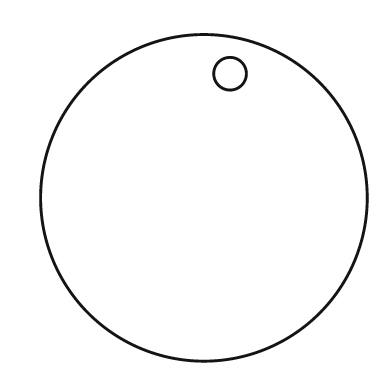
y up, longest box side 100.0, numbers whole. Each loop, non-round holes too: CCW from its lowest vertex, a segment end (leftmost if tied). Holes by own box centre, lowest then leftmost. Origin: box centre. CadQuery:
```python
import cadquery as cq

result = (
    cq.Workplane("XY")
    .moveTo(0.0, 0.0)
    .circle(50.0)
    .moveTo(8.0, 38.0)
    .circle(5.0)
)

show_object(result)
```